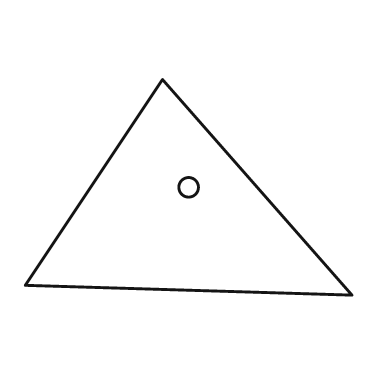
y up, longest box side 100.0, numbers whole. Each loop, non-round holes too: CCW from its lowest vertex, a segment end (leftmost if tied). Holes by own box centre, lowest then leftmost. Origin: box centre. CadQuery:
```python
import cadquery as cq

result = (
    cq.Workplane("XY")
    .moveTo(50.0, -33.0)
    .lineTo(-8.0, 33.0)
    .lineTo(-50.0, -30.0)
    .close()
    .moveTo(0.0, 0.0)
    .circle(3.0)
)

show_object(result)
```